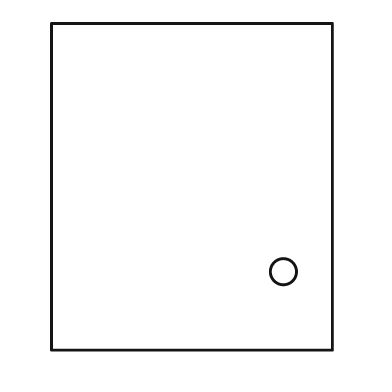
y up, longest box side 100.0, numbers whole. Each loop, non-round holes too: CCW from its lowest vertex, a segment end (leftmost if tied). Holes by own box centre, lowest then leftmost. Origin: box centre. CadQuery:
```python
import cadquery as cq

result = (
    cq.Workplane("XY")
    .moveTo(-43.0, -50.0)
    .lineTo(43.0, -50.0)
    .lineTo(43.0, 50.0)
    .lineTo(-43.0, 50.0)
    .close()
    .moveTo(28.0, -26.0)
    .circle(4.0)
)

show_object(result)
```